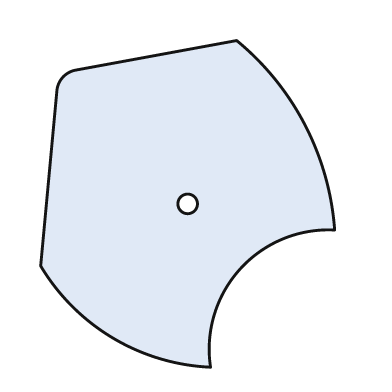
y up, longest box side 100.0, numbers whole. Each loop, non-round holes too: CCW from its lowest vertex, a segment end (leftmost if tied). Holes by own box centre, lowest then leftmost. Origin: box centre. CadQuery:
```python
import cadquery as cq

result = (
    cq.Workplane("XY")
    .moveTo(7.0, -50.0)
    .threePointArc((16.0, -20.0), (45.0, -8.0))
    .threePointArc((36.0, 24.0), (15.0, 50.0))
    .lineTo(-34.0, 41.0)
    .threePointArc((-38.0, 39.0), (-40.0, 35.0))
    .lineTo(-45.0, -19.0)
    .threePointArc((-23.0, -41.0), (7.0, -50.0))
    .close()
    .moveTo(0.0, 0.0)
    .circle(3.0)
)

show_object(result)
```